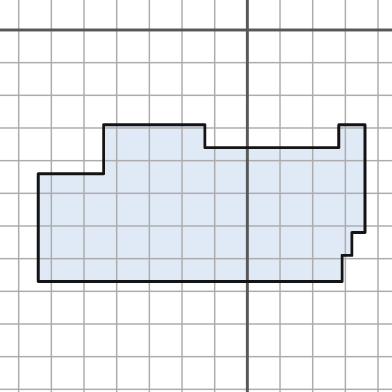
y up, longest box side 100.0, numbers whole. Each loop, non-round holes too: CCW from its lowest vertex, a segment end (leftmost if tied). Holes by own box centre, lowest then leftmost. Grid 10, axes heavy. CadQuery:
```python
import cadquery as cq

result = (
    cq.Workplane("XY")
    .moveTo(-64.0, -77.0)
    .lineTo(29.0, -77.0)
    .lineTo(29.0, -69.0)
    .lineTo(32.0, -69.0)
    .lineTo(32.0, -62.0)
    .lineTo(36.0, -62.0)
    .lineTo(36.0, -29.0)
    .lineTo(28.0, -29.0)
    .lineTo(28.0, -36.0)
    .lineTo(-13.0, -36.0)
    .lineTo(-13.0, -29.0)
    .lineTo(-44.0, -29.0)
    .lineTo(-44.0, -44.0)
    .lineTo(-64.0, -44.0)
    .close()
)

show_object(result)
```